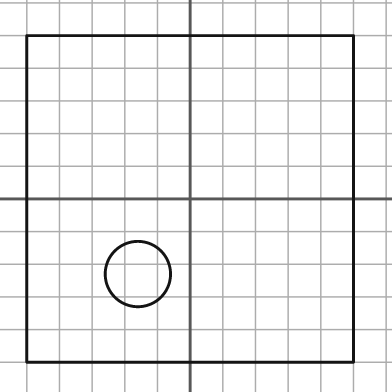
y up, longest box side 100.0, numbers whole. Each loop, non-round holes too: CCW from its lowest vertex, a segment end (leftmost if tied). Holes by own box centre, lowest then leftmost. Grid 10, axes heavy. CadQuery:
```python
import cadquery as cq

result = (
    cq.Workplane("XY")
    .moveTo(-50.0, -50.0)
    .lineTo(50.0, -50.0)
    .lineTo(50.0, 50.0)
    .lineTo(-50.0, 50.0)
    .close()
    .moveTo(-16.0, -23.0)
    .circle(10.0)
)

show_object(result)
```